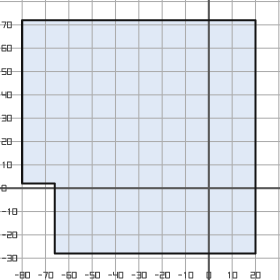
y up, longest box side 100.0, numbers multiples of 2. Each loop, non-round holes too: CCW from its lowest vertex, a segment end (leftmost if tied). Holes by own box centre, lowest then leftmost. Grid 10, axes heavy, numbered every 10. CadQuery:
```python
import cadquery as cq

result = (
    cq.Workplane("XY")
    .moveTo(-66.0, -28.0)
    .lineTo(20.0, -28.0)
    .lineTo(20.0, 72.0)
    .lineTo(-80.0, 72.0)
    .lineTo(-80.0, 2.0)
    .lineTo(-66.0, 2.0)
    .close()
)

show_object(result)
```